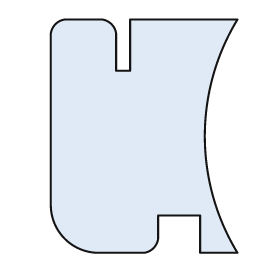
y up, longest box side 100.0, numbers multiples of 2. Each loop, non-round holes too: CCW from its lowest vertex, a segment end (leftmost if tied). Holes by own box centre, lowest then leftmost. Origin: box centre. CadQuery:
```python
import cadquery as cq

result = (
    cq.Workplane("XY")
    .moveTo(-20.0, -50.0)
    .lineTo(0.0, -50.0)
    .threePointArc((4.0, -48.0), (6.0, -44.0))
    .lineTo(6.0, -34.0)
    .lineTo(24.0, -34.0)
    .lineTo(24.0, -50.0)
    .lineTo(40.0, -50.0)
    .threePointArc((26.0, 0.0), (40.0, 50.0))
    .lineTo(-6.0, 50.0)
    .lineTo(-6.0, 28.0)
    .lineTo(-12.0, 28.0)
    .lineTo(-12.0, 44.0)
    .threePointArc((-14.0, 48.0), (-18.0, 50.0))
    .lineTo(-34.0, 50.0)
    .threePointArc((-38.0, 48.0), (-40.0, 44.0))
    .lineTo(-40.0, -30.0)
    .threePointArc((-34.0, -44.0), (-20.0, -50.0))
    .close()
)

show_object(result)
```